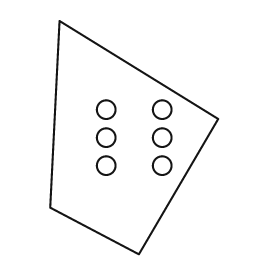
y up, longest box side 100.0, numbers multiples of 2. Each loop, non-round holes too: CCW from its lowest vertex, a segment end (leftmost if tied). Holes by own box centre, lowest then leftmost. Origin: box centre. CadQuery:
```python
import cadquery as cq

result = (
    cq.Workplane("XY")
    .moveTo(2.0, -50.0)
    .lineTo(36.0, 8.0)
    .lineTo(-32.0, 50.0)
    .lineTo(-36.0, -30.0)
    .close()
    .moveTo(-12.0, -12.0)
    .circle(4.0)
    .moveTo(12.0, -12.0)
    .circle(4.0)
    .moveTo(-12.0, 0.0)
    .circle(4.0)
    .moveTo(12.0, 0.0)
    .circle(4.0)
    .moveTo(-12.0, 12.0)
    .circle(4.0)
    .moveTo(12.0, 12.0)
    .circle(4.0)
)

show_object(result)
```